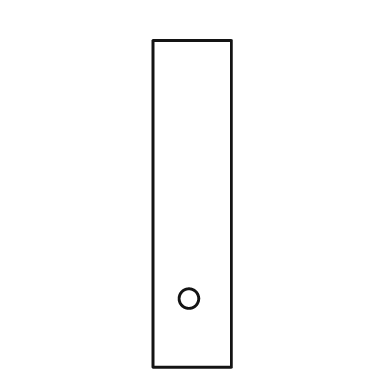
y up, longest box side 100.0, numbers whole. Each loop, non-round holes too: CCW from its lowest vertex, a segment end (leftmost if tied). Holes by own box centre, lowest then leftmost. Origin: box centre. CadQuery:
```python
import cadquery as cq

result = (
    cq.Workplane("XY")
    .moveTo(-12.0, -50.0)
    .lineTo(12.0, -50.0)
    .lineTo(12.0, 50.0)
    .lineTo(-12.0, 50.0)
    .close()
    .moveTo(-1.0, -29.0)
    .circle(3.0)
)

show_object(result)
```